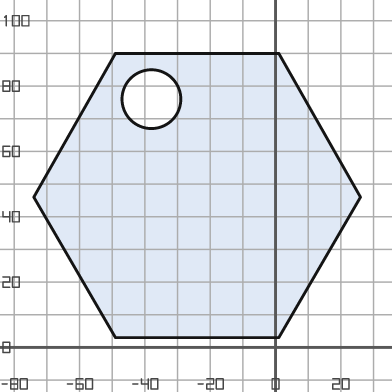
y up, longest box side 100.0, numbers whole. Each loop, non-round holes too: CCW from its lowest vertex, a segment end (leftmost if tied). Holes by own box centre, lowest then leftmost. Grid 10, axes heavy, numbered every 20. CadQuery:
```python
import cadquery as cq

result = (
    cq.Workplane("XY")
    .moveTo(-49.0, 3.0)
    .lineTo(1.0, 3.0)
    .lineTo(26.0, 46.0)
    .lineTo(1.0, 90.0)
    .lineTo(-49.0, 90.0)
    .lineTo(-74.0, 46.0)
    .close()
    .moveTo(-38.0, 76.0)
    .circle(9.0)
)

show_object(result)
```